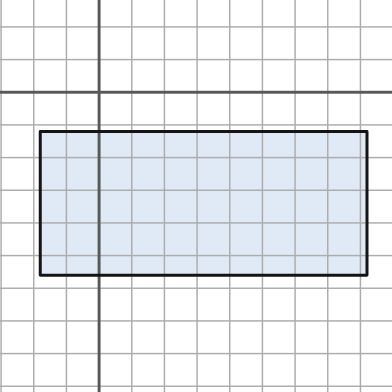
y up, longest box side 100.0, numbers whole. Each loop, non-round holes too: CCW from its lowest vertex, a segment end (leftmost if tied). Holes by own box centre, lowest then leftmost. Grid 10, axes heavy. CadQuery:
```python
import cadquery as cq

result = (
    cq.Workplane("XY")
    .moveTo(-18.0, -56.0)
    .lineTo(82.0, -56.0)
    .lineTo(82.0, -12.0)
    .lineTo(-18.0, -12.0)
    .close()
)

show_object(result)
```